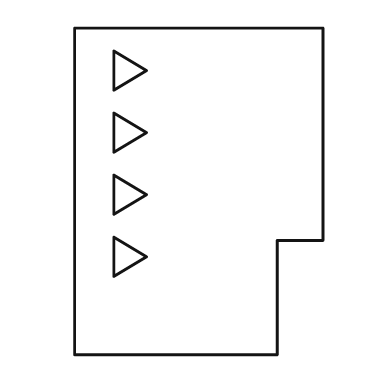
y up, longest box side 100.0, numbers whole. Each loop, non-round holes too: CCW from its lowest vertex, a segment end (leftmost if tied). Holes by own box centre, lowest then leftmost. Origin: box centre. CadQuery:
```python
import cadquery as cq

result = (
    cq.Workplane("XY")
    .moveTo(-38.0, -50.0)
    .lineTo(24.0, -50.0)
    .lineTo(24.0, -15.0)
    .lineTo(38.0, -15.0)
    .lineTo(38.0, 50.0)
    .lineTo(-38.0, 50.0)
    .close()
    .moveTo(-26.0, -26.0)
    .lineTo(-16.0, -20.0)
    .lineTo(-26.0, -14.0)
    .close()
    .moveTo(-26.0, -7.0)
    .lineTo(-16.0, -1.0)
    .lineTo(-26.0, 5.0)
    .close()
    .moveTo(-26.0, 12.0)
    .lineTo(-16.0, 18.0)
    .lineTo(-26.0, 24.0)
    .close()
    .moveTo(-26.0, 31.0)
    .lineTo(-16.0, 37.0)
    .lineTo(-26.0, 43.0)
    .close()
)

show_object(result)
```